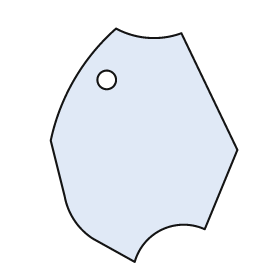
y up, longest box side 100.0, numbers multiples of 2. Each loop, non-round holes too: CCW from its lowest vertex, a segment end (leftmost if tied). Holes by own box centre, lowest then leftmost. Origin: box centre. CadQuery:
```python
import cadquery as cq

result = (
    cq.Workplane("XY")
    .moveTo(-4.0, -50.0)
    .threePointArc((8.0, -36.0), (26.0, -36.0))
    .lineTo(40.0, -2.0)
    .lineTo(16.0, 48.0)
    .threePointArc((2.0, 46.0), (-12.0, 50.0))
    .threePointArc((-30.0, 28.0), (-40.0, 2.0))
    .lineTo(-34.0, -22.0)
    .threePointArc((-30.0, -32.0), (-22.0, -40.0))
    .close()
    .moveTo(-16.0, 28.0)
    .circle(4.0)
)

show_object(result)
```